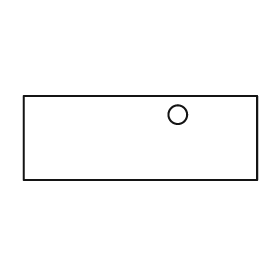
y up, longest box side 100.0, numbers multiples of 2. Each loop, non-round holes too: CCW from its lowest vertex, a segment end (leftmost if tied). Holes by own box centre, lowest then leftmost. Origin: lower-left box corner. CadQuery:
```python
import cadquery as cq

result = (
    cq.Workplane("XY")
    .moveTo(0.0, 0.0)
    .lineTo(100.0, 0.0)
    .lineTo(100.0, 36.0)
    .lineTo(0.0, 36.0)
    .close()
    .moveTo(66.0, 28.0)
    .circle(4.0)
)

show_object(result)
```